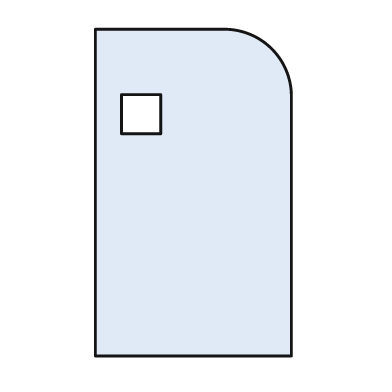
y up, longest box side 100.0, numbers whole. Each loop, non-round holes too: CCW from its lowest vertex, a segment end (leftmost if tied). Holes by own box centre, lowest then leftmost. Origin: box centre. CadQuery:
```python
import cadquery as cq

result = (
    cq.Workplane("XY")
    .moveTo(-30.0, -50.0)
    .lineTo(30.0, -50.0)
    .lineTo(30.0, 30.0)
    .threePointArc((24.0, 44.0), (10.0, 50.0))
    .lineTo(-30.0, 50.0)
    .close()
    .moveTo(-22.0, 18.0)
    .lineTo(-10.0, 18.0)
    .lineTo(-10.0, 30.0)
    .lineTo(-22.0, 30.0)
    .close()
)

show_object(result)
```